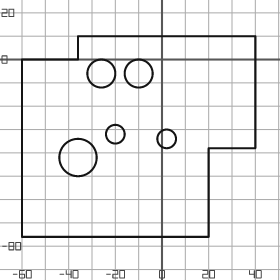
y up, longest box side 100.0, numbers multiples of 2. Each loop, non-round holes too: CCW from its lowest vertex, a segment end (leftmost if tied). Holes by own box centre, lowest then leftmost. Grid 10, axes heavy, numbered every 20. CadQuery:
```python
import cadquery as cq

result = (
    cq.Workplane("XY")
    .moveTo(-60.0, -76.0)
    .lineTo(20.0, -76.0)
    .lineTo(20.0, -38.0)
    .lineTo(40.0, -38.0)
    .lineTo(40.0, 10.0)
    .lineTo(-36.0, 10.0)
    .lineTo(-36.0, 0.0)
    .lineTo(-60.0, 0.0)
    .close()
    .moveTo(-36.0, -42.0)
    .circle(8.0)
    .moveTo(2.0, -34.0)
    .circle(4.0)
    .moveTo(-20.0, -32.0)
    .circle(4.0)
    .moveTo(-26.0, -6.0)
    .circle(6.0)
    .moveTo(-10.0, -6.0)
    .circle(6.0)
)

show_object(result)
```